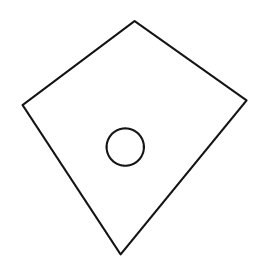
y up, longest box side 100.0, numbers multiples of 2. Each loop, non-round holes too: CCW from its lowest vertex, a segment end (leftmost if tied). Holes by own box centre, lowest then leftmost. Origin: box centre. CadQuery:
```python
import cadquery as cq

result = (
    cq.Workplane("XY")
    .moveTo(-6.0, -50.0)
    .lineTo(48.0, 16.0)
    .lineTo(0.0, 50.0)
    .lineTo(-48.0, 14.0)
    .close()
    .moveTo(-4.0, -4.0)
    .circle(8.0)
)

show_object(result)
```